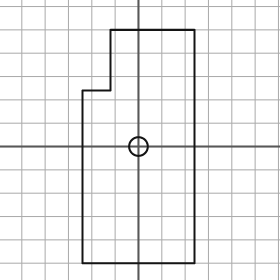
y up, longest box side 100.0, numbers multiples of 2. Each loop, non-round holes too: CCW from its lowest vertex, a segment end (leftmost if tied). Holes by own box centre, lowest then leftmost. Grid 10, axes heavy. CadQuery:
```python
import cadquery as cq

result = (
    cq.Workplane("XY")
    .moveTo(-24.0, -50.0)
    .lineTo(24.0, -50.0)
    .lineTo(24.0, 50.0)
    .lineTo(-12.0, 50.0)
    .lineTo(-12.0, 24.0)
    .lineTo(-24.0, 24.0)
    .close()
    .moveTo(0.0, 0.0)
    .circle(4.0)
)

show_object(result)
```